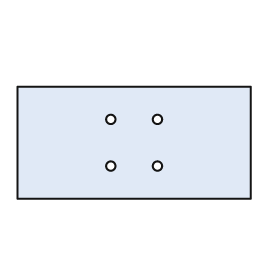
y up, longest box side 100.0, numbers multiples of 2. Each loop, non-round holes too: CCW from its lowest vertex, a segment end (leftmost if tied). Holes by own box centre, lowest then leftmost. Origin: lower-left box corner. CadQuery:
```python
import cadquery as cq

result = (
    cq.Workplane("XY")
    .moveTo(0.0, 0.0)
    .lineTo(100.0, 0.0)
    .lineTo(100.0, 48.0)
    .lineTo(0.0, 48.0)
    .close()
    .moveTo(40.0, 14.0)
    .circle(2.0)
    .moveTo(60.0, 14.0)
    .circle(2.0)
    .moveTo(40.0, 34.0)
    .circle(2.0)
    .moveTo(60.0, 34.0)
    .circle(2.0)
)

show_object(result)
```